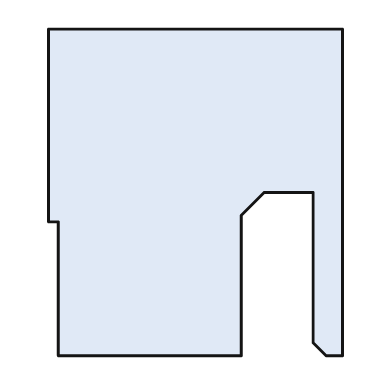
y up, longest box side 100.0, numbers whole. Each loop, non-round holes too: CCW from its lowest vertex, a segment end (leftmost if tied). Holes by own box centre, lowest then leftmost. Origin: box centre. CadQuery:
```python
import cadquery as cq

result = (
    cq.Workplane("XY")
    .moveTo(-42.0, -50.0)
    .lineTo(14.0, -50.0)
    .lineTo(14.0, -7.0)
    .lineTo(21.0, 0.0)
    .lineTo(36.0, 0.0)
    .lineTo(36.0, -46.0)
    .lineTo(40.0, -50.0)
    .lineTo(45.0, -50.0)
    .lineTo(45.0, 50.0)
    .lineTo(-45.0, 50.0)
    .lineTo(-45.0, -9.0)
    .lineTo(-42.0, -9.0)
    .close()
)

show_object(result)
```